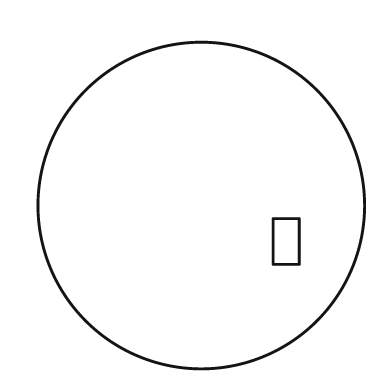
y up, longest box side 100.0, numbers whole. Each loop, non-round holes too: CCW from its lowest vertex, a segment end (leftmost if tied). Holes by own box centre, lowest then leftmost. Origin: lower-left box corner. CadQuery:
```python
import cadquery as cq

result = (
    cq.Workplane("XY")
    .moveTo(50.0, 50.0)
    .circle(50.0)
    .moveTo(72.0, 32.0)
    .lineTo(80.0, 32.0)
    .lineTo(80.0, 46.0)
    .lineTo(72.0, 46.0)
    .close()
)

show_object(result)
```